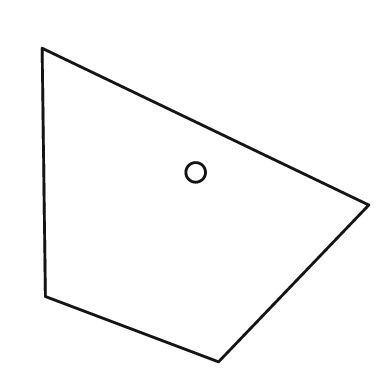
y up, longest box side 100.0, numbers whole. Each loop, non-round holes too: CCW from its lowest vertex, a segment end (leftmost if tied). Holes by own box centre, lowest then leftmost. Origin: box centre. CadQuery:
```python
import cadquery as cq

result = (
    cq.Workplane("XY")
    .moveTo(4.0, -48.0)
    .lineTo(50.0, 0.0)
    .lineTo(-50.0, 48.0)
    .lineTo(-49.0, -28.0)
    .close()
    .moveTo(-3.0, 10.0)
    .circle(3.0)
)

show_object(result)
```